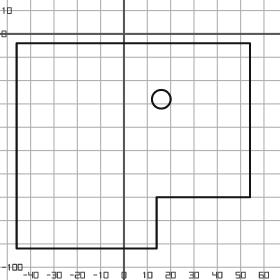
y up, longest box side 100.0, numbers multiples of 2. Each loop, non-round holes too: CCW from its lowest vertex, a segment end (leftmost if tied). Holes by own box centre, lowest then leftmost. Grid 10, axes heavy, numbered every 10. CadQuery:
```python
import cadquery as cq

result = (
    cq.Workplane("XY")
    .moveTo(-46.0, -92.0)
    .lineTo(14.0, -92.0)
    .lineTo(14.0, -70.0)
    .lineTo(54.0, -70.0)
    .lineTo(54.0, -4.0)
    .lineTo(-46.0, -4.0)
    .close()
    .moveTo(16.0, -28.0)
    .circle(4.0)
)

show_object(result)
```